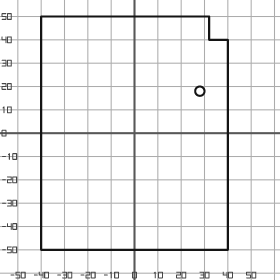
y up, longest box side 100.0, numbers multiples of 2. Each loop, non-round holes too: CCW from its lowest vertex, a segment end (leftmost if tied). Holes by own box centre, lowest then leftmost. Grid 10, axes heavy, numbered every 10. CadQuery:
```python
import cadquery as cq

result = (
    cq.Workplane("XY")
    .moveTo(-40.0, -50.0)
    .lineTo(40.0, -50.0)
    .lineTo(40.0, 40.0)
    .lineTo(32.0, 40.0)
    .lineTo(32.0, 50.0)
    .lineTo(-40.0, 50.0)
    .close()
    .moveTo(28.0, 18.0)
    .circle(2.0)
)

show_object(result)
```